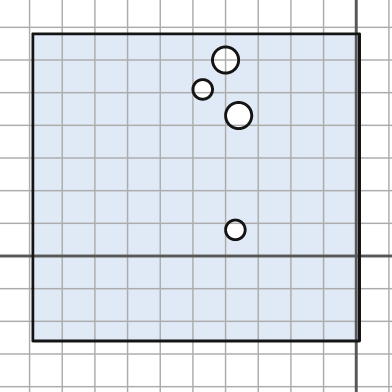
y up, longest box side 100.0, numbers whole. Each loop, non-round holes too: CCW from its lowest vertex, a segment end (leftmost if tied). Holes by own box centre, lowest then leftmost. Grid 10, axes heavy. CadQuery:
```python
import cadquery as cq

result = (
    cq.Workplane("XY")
    .moveTo(-99.0, -26.0)
    .lineTo(1.0, -26.0)
    .lineTo(1.0, 68.0)
    .lineTo(-99.0, 68.0)
    .close()
    .moveTo(-37.0, 8.0)
    .circle(3.0)
    .moveTo(-36.0, 43.0)
    .circle(4.0)
    .moveTo(-47.0, 51.0)
    .circle(3.0)
    .moveTo(-40.0, 60.0)
    .circle(4.0)
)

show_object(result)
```